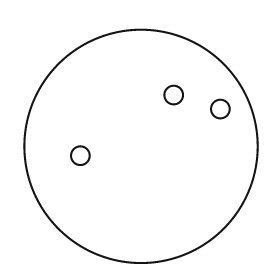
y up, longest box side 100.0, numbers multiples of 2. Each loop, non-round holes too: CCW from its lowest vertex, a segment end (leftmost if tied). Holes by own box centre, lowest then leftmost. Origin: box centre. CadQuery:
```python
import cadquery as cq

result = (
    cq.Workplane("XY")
    .moveTo(0.0, 0.0)
    .circle(50.0)
    .moveTo(-26.0, -4.0)
    .circle(4.0)
    .moveTo(34.0, 16.0)
    .circle(4.0)
    .moveTo(14.0, 22.0)
    .circle(4.0)
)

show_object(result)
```